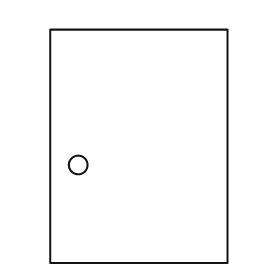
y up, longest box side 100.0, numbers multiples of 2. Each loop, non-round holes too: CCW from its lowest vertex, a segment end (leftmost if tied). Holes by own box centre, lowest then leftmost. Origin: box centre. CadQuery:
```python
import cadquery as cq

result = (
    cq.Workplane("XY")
    .moveTo(-38.0, -50.0)
    .lineTo(38.0, -50.0)
    .lineTo(38.0, 50.0)
    .lineTo(-38.0, 50.0)
    .close()
    .moveTo(-26.0, -8.0)
    .circle(4.0)
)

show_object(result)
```